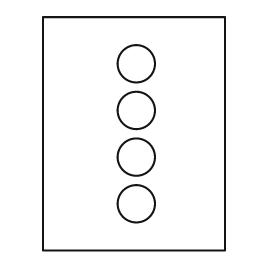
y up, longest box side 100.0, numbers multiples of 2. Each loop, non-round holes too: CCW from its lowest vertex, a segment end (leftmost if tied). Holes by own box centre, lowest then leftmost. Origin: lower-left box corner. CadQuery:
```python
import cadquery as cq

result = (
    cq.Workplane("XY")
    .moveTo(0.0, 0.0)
    .lineTo(78.0, 0.0)
    .lineTo(78.0, 100.0)
    .lineTo(0.0, 100.0)
    .close()
    .moveTo(40.0, 20.0)
    .circle(8.0)
    .moveTo(40.0, 40.0)
    .circle(8.0)
    .moveTo(40.0, 60.0)
    .circle(8.0)
    .moveTo(40.0, 80.0)
    .circle(8.0)
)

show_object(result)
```